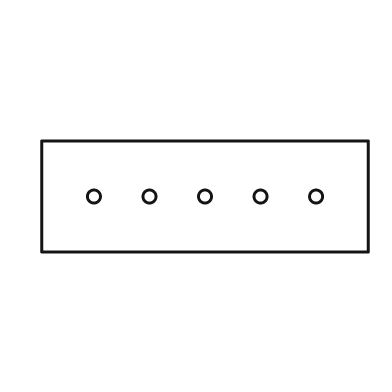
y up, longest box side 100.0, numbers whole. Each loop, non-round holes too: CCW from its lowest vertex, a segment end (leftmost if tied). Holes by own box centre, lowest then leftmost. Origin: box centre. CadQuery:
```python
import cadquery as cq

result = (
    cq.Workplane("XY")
    .moveTo(-50.0, -17.0)
    .lineTo(50.0, -17.0)
    .lineTo(50.0, 17.0)
    .lineTo(-50.0, 17.0)
    .close()
    .moveTo(-34.0, 0.0)
    .circle(2.0)
    .moveTo(-17.0, 0.0)
    .circle(2.0)
    .moveTo(0.0, 0.0)
    .circle(2.0)
    .moveTo(17.0, 0.0)
    .circle(2.0)
    .moveTo(34.0, 0.0)
    .circle(2.0)
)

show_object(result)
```